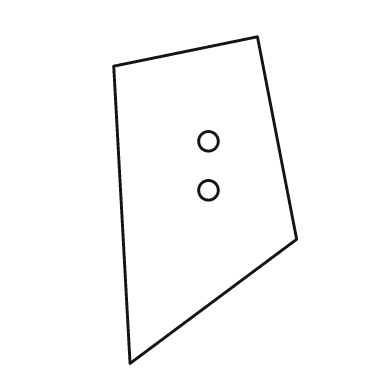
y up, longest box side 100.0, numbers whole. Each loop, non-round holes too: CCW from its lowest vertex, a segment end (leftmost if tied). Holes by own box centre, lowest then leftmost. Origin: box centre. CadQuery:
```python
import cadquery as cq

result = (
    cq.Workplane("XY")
    .moveTo(-23.0, -50.0)
    .lineTo(28.0, -12.0)
    .lineTo(16.0, 50.0)
    .lineTo(-28.0, 41.0)
    .close()
    .moveTo(1.0, 3.0)
    .circle(3.0)
    .moveTo(1.0, 18.0)
    .circle(3.0)
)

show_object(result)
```